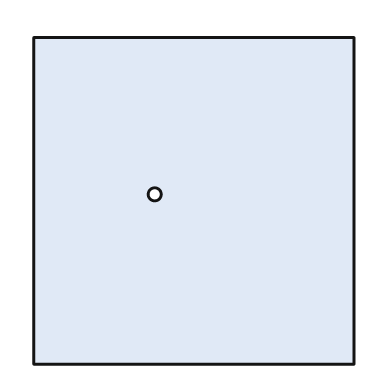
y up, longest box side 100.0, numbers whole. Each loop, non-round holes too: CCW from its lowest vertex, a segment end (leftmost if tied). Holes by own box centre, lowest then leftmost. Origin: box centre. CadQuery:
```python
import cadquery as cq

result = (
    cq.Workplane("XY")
    .moveTo(-49.0, -50.0)
    .lineTo(49.0, -50.0)
    .lineTo(49.0, 50.0)
    .lineTo(-49.0, 50.0)
    .close()
    .moveTo(-12.0, 2.0)
    .circle(2.0)
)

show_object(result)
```